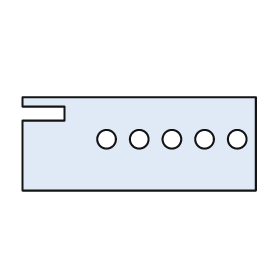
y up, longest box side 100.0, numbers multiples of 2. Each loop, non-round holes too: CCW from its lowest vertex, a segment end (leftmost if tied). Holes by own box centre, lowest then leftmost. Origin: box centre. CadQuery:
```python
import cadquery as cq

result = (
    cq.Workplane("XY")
    .moveTo(-50.0, -20.0)
    .lineTo(50.0, -20.0)
    .lineTo(50.0, 20.0)
    .lineTo(-50.0, 20.0)
    .lineTo(-50.0, 16.0)
    .lineTo(-32.0, 16.0)
    .lineTo(-32.0, 10.0)
    .lineTo(-50.0, 10.0)
    .close()
    .moveTo(-14.0, 2.0)
    .circle(4.0)
    .moveTo(0.0, 2.0)
    .circle(4.0)
    .moveTo(14.0, 2.0)
    .circle(4.0)
    .moveTo(28.0, 2.0)
    .circle(4.0)
    .moveTo(42.0, 2.0)
    .circle(4.0)
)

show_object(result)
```